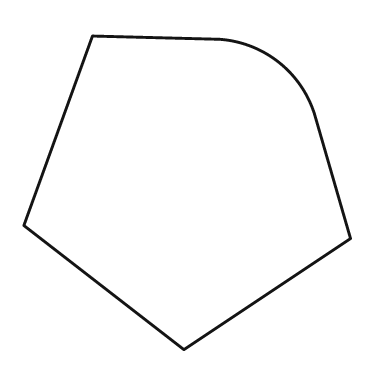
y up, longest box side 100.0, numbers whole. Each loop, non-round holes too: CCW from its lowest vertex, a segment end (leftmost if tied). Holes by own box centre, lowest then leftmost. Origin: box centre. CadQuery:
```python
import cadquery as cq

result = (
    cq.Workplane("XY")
    .moveTo(-1.0, -48.0)
    .lineTo(50.0, -14.0)
    .lineTo(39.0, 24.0)
    .threePointArc((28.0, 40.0), (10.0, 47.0))
    .lineTo(-29.0, 48.0)
    .lineTo(-50.0, -10.0)
    .close()
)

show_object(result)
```